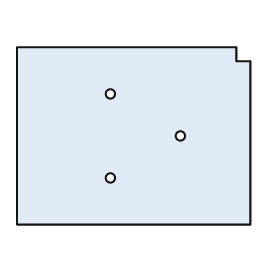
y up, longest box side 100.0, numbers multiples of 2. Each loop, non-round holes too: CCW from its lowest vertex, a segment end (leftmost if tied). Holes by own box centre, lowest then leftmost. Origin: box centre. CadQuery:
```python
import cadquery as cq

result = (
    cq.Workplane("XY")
    .moveTo(-50.0, -38.0)
    .lineTo(50.0, -38.0)
    .lineTo(50.0, 32.0)
    .lineTo(44.0, 32.0)
    .lineTo(44.0, 38.0)
    .lineTo(-50.0, 38.0)
    .close()
    .moveTo(-10.0, -18.0)
    .circle(2.0)
    .moveTo(20.0, 0.0)
    .circle(2.0)
    .moveTo(-10.0, 18.0)
    .circle(2.0)
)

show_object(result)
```